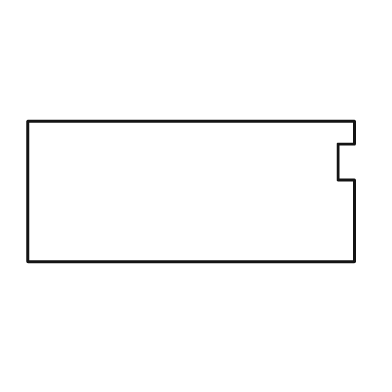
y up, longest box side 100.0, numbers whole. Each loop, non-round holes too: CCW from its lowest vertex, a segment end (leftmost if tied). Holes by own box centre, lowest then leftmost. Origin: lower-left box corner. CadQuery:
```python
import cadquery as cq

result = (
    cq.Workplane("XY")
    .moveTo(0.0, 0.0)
    .lineTo(100.0, 0.0)
    .lineTo(100.0, 25.0)
    .lineTo(95.0, 25.0)
    .lineTo(95.0, 36.0)
    .lineTo(100.0, 36.0)
    .lineTo(100.0, 43.0)
    .lineTo(0.0, 43.0)
    .close()
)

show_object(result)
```